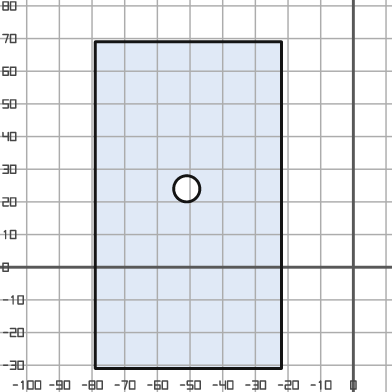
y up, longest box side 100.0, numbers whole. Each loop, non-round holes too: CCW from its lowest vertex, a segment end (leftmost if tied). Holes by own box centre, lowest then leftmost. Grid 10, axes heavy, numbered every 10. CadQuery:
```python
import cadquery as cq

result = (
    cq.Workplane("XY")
    .moveTo(-79.0, -31.0)
    .lineTo(-22.0, -31.0)
    .lineTo(-22.0, 69.0)
    .lineTo(-79.0, 69.0)
    .close()
    .moveTo(-51.0, 24.0)
    .circle(4.0)
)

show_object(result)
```